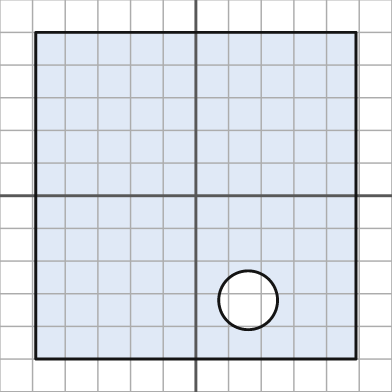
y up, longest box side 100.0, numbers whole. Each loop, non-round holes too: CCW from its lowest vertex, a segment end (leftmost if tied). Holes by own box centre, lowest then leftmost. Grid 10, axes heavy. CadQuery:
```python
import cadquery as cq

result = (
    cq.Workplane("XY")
    .moveTo(-49.0, -50.0)
    .lineTo(49.0, -50.0)
    .lineTo(49.0, 50.0)
    .lineTo(-49.0, 50.0)
    .close()
    .moveTo(16.0, -32.0)
    .circle(9.0)
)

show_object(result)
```